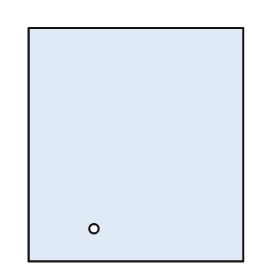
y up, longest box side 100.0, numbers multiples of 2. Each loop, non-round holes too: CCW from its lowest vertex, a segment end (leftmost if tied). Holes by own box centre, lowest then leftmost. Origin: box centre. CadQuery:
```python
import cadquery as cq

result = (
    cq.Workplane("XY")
    .moveTo(-46.0, -50.0)
    .lineTo(46.0, -50.0)
    .lineTo(46.0, 50.0)
    .lineTo(-46.0, 50.0)
    .close()
    .moveTo(-18.0, -36.0)
    .circle(2.0)
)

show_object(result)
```